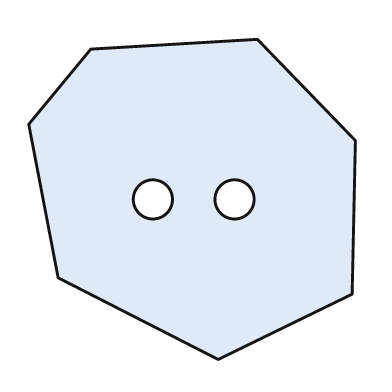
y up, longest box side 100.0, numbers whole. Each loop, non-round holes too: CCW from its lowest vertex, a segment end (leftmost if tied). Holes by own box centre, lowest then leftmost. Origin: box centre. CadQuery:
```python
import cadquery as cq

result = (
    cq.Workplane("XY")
    .moveTo(8.0, -49.0)
    .lineTo(49.0, -29.0)
    .lineTo(50.0, 18.0)
    .lineTo(20.0, 49.0)
    .lineTo(-31.0, 46.0)
    .lineTo(-50.0, 23.0)
    .lineTo(-41.0, -24.0)
    .close()
    .moveTo(-12.0, 0.0)
    .circle(6.0)
    .moveTo(13.0, 0.0)
    .circle(6.0)
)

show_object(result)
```